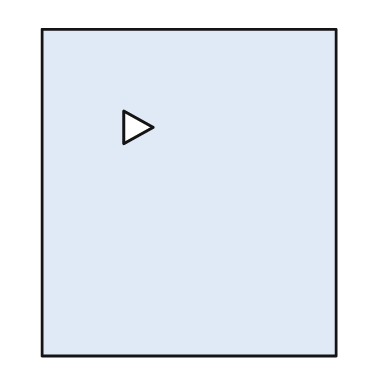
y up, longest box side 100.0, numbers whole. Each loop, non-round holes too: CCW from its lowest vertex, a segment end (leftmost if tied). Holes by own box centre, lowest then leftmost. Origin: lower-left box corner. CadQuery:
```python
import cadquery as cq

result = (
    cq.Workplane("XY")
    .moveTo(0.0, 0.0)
    .lineTo(90.0, 0.0)
    .lineTo(90.0, 100.0)
    .lineTo(0.0, 100.0)
    .close()
    .moveTo(25.0, 65.0)
    .lineTo(34.0, 70.0)
    .lineTo(25.0, 75.0)
    .close()
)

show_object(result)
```